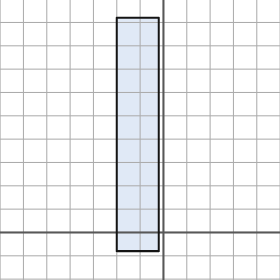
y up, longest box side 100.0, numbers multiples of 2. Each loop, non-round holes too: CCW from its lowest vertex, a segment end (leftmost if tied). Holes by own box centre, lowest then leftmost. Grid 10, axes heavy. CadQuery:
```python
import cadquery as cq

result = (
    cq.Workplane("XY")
    .moveTo(-20.0, -8.0)
    .lineTo(-2.0, -8.0)
    .lineTo(-2.0, 92.0)
    .lineTo(-20.0, 92.0)
    .close()
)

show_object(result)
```